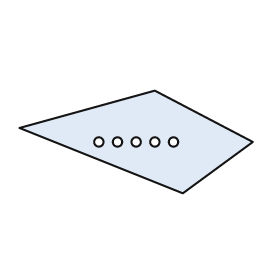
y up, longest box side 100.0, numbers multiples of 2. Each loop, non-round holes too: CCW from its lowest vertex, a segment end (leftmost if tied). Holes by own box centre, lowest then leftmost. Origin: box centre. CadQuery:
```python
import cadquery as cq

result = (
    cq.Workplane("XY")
    .moveTo(20.0, -22.0)
    .lineTo(50.0, 0.0)
    .lineTo(8.0, 22.0)
    .lineTo(-50.0, 6.0)
    .close()
    .moveTo(-16.0, 0.0)
    .circle(2.0)
    .moveTo(-8.0, 0.0)
    .circle(2.0)
    .moveTo(0.0, 0.0)
    .circle(2.0)
    .moveTo(8.0, 0.0)
    .circle(2.0)
    .moveTo(16.0, 0.0)
    .circle(2.0)
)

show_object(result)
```